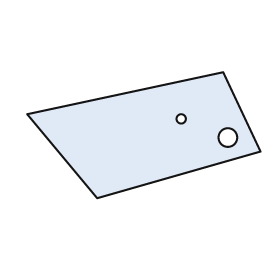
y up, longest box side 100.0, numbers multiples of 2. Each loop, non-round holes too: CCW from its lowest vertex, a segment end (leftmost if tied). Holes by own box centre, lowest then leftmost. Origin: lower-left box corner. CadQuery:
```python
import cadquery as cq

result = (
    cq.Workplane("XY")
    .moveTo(30.0, 0.0)
    .lineTo(100.0, 20.0)
    .lineTo(84.0, 54.0)
    .lineTo(0.0, 36.0)
    .close()
    .moveTo(86.0, 26.0)
    .circle(4.0)
    .moveTo(66.0, 34.0)
    .circle(2.0)
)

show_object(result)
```